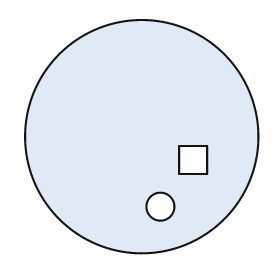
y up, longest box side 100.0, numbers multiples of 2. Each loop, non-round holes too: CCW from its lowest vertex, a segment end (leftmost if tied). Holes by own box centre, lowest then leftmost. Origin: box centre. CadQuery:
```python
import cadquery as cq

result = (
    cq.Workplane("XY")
    .moveTo(0.0, 0.0)
    .circle(50.0)
    .moveTo(8.0, -30.0)
    .circle(6.0)
    .moveTo(16.0, -16.0)
    .lineTo(28.0, -16.0)
    .lineTo(28.0, -4.0)
    .lineTo(16.0, -4.0)
    .close()
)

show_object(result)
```